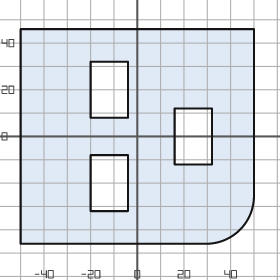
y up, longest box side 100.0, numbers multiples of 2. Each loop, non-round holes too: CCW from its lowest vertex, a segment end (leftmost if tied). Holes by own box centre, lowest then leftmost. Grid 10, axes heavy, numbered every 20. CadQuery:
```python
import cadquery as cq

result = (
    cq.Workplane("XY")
    .moveTo(-50.0, -46.0)
    .lineTo(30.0, -46.0)
    .threePointArc((44.0, -40.0), (50.0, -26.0))
    .lineTo(50.0, 46.0)
    .lineTo(-50.0, 46.0)
    .close()
    .moveTo(-20.0, -32.0)
    .lineTo(-4.0, -32.0)
    .lineTo(-4.0, -8.0)
    .lineTo(-20.0, -8.0)
    .close()
    .moveTo(16.0, -12.0)
    .lineTo(32.0, -12.0)
    .lineTo(32.0, 12.0)
    .lineTo(16.0, 12.0)
    .close()
    .moveTo(-20.0, 8.0)
    .lineTo(-4.0, 8.0)
    .lineTo(-4.0, 32.0)
    .lineTo(-20.0, 32.0)
    .close()
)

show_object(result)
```